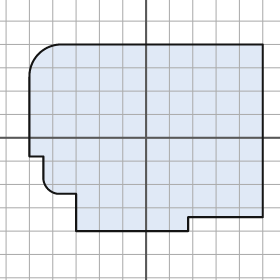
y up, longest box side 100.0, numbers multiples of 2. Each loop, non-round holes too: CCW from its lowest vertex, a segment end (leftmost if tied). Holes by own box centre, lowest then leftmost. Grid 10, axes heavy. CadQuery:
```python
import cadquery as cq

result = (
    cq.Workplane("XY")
    .moveTo(-30.0, -40.0)
    .lineTo(18.0, -40.0)
    .lineTo(18.0, -34.0)
    .lineTo(50.0, -34.0)
    .lineTo(50.0, 40.0)
    .lineTo(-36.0, 40.0)
    .threePointArc((-46.0, 36.0), (-50.0, 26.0))
    .lineTo(-50.0, -8.0)
    .lineTo(-44.0, -8.0)
    .lineTo(-44.0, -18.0)
    .threePointArc((-42.0, -22.0), (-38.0, -24.0))
    .lineTo(-30.0, -24.0)
    .close()
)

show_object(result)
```